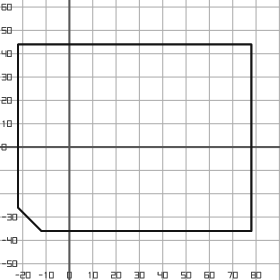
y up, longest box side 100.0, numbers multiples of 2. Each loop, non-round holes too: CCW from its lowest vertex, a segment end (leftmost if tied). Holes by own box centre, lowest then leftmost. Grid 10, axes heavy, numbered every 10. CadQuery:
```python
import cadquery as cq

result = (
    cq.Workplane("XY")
    .moveTo(-12.0, -36.0)
    .lineTo(78.0, -36.0)
    .lineTo(78.0, 44.0)
    .lineTo(-22.0, 44.0)
    .lineTo(-22.0, -26.0)
    .close()
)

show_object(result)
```